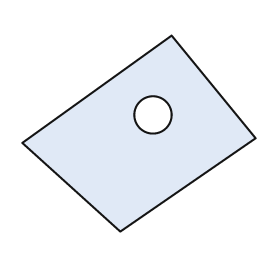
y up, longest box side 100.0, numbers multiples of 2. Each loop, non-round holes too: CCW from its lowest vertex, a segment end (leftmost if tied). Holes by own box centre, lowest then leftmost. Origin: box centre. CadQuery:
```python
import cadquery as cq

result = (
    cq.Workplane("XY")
    .moveTo(-8.0, -42.0)
    .lineTo(50.0, -2.0)
    .lineTo(14.0, 42.0)
    .lineTo(-50.0, -4.0)
    .close()
    .moveTo(6.0, 8.0)
    .circle(8.0)
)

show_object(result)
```